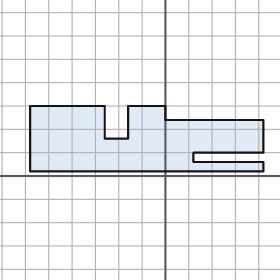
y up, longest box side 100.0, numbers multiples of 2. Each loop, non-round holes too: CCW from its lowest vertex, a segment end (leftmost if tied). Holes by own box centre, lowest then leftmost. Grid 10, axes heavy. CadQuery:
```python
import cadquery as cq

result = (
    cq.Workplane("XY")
    .moveTo(-58.0, 2.0)
    .lineTo(42.0, 2.0)
    .lineTo(42.0, 6.0)
    .lineTo(12.0, 6.0)
    .lineTo(12.0, 10.0)
    .lineTo(42.0, 10.0)
    .lineTo(42.0, 24.0)
    .lineTo(0.0, 24.0)
    .lineTo(0.0, 30.0)
    .lineTo(-16.0, 30.0)
    .lineTo(-16.0, 16.0)
    .lineTo(-26.0, 16.0)
    .lineTo(-26.0, 30.0)
    .lineTo(-58.0, 30.0)
    .close()
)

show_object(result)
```